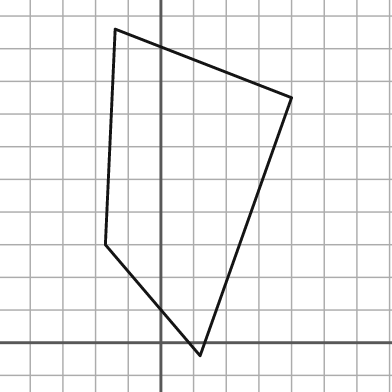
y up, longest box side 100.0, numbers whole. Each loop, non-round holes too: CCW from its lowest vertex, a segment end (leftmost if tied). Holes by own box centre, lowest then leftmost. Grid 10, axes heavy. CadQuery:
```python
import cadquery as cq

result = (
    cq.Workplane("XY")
    .moveTo(12.0, -4.0)
    .lineTo(40.0, 75.0)
    .lineTo(-14.0, 96.0)
    .lineTo(-17.0, 30.0)
    .close()
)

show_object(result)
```